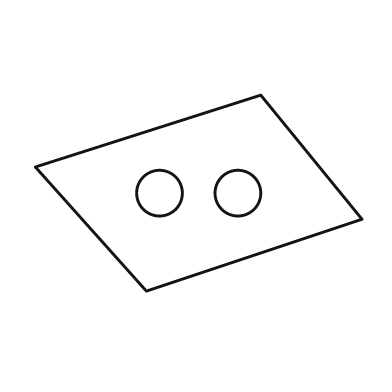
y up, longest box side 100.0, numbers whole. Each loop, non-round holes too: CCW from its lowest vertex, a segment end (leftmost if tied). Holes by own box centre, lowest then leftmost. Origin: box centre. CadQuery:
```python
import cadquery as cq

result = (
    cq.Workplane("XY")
    .moveTo(-16.0, -30.0)
    .lineTo(50.0, -8.0)
    .lineTo(19.0, 30.0)
    .lineTo(-50.0, 8.0)
    .close()
    .moveTo(-12.0, 0.0)
    .circle(7.0)
    .moveTo(12.0, 0.0)
    .circle(7.0)
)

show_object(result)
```